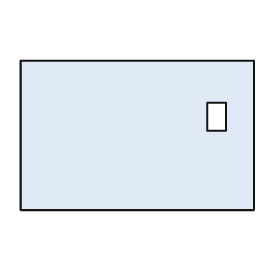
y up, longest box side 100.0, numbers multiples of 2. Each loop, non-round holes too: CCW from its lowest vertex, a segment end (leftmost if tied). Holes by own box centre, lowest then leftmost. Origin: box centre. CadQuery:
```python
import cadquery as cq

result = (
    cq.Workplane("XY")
    .moveTo(-50.0, -32.0)
    .lineTo(50.0, -32.0)
    .lineTo(50.0, 32.0)
    .lineTo(-50.0, 32.0)
    .close()
    .moveTo(30.0, 2.0)
    .lineTo(38.0, 2.0)
    .lineTo(38.0, 14.0)
    .lineTo(30.0, 14.0)
    .close()
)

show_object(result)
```